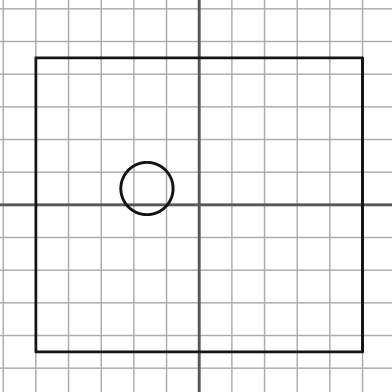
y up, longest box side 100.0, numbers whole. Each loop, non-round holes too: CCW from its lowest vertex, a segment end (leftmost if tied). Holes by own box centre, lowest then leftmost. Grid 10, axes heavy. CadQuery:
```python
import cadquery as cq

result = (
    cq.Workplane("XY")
    .moveTo(-50.0, -45.0)
    .lineTo(50.0, -45.0)
    .lineTo(50.0, 45.0)
    .lineTo(-50.0, 45.0)
    .close()
    .moveTo(-16.0, 5.0)
    .circle(8.0)
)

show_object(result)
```